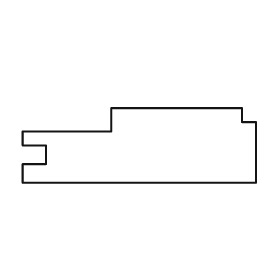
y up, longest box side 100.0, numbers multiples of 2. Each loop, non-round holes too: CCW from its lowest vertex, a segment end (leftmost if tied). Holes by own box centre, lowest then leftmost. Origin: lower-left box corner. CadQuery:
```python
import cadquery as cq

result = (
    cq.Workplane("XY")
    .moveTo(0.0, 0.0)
    .lineTo(100.0, 0.0)
    .lineTo(100.0, 26.0)
    .lineTo(94.0, 26.0)
    .lineTo(94.0, 32.0)
    .lineTo(38.0, 32.0)
    .lineTo(38.0, 22.0)
    .lineTo(0.0, 22.0)
    .lineTo(0.0, 16.0)
    .lineTo(10.0, 16.0)
    .lineTo(10.0, 8.0)
    .lineTo(0.0, 8.0)
    .close()
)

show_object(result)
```